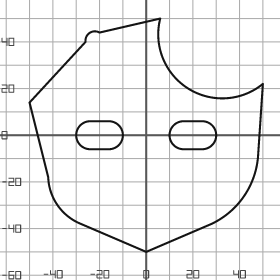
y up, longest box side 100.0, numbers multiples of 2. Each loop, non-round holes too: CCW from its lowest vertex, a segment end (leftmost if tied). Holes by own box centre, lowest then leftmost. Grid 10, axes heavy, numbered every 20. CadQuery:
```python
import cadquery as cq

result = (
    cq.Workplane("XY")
    .moveTo(0.0, -50.0)
    .lineTo(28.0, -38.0)
    .threePointArc((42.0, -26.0), (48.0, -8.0))
    .lineTo(50.0, 22.0)
    .threePointArc((18.0, 20.0), (6.0, 50.0))
    .lineTo(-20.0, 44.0)
    .threePointArc((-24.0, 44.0), (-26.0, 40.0))
    .lineTo(-50.0, 14.0)
    .lineTo(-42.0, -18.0)
    .threePointArc((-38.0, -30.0), (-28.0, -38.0))
    .close()
    .moveTo(-24.0, -6.0)
    .lineTo(-16.0, -6.0)
    .threePointArc((-10.0, 0.0), (-16.0, 6.0))
    .lineTo(-24.0, 6.0)
    .threePointArc((-30.0, 0.0), (-24.0, -6.0))
    .close()
    .moveTo(16.0, -6.0)
    .lineTo(24.0, -6.0)
    .threePointArc((30.0, 0.0), (24.0, 6.0))
    .lineTo(16.0, 6.0)
    .threePointArc((10.0, 0.0), (16.0, -6.0))
    .close()
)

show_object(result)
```